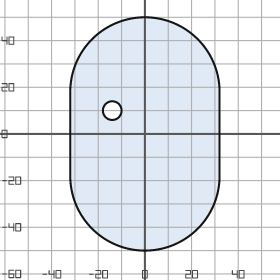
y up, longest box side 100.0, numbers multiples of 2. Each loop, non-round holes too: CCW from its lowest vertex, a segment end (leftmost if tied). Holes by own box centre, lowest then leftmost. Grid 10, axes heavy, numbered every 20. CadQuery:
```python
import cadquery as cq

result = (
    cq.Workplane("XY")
    .moveTo(-32.0, -18.0)
    .threePointArc((0.0, -50.0), (32.0, -18.0))
    .lineTo(32.0, 18.0)
    .threePointArc((0.0, 50.0), (-32.0, 18.0))
    .close()
    .moveTo(-14.0, 10.0)
    .circle(4.0)
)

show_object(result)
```